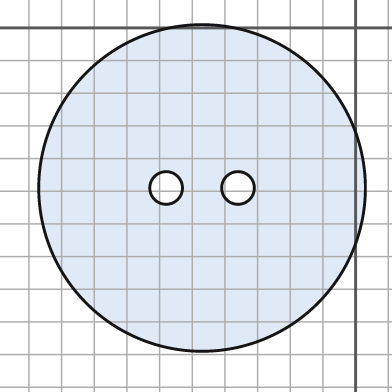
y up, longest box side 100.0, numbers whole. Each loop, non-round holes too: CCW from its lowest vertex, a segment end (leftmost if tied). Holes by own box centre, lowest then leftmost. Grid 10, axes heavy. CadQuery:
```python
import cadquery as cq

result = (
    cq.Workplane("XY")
    .moveTo(-47.0, -49.0)
    .circle(50.0)
    .moveTo(-58.0, -49.0)
    .circle(5.0)
    .moveTo(-36.0, -49.0)
    .circle(5.0)
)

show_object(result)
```